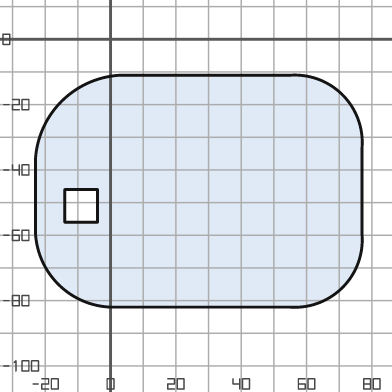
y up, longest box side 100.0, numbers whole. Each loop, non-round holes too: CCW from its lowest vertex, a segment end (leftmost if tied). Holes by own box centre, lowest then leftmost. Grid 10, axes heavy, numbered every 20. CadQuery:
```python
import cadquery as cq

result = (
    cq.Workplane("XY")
    .moveTo(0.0, -82.0)
    .lineTo(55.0, -82.0)
    .threePointArc((71.0, -76.0), (77.0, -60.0))
    .lineTo(77.0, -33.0)
    .threePointArc((71.0, -17.0), (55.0, -11.0))
    .lineTo(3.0, -11.0)
    .threePointArc((-15.0, -19.0), (-23.0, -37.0))
    .lineTo(-23.0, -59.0)
    .threePointArc((-16.0, -75.0), (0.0, -82.0))
    .close()
    .moveTo(-14.0, -56.0)
    .lineTo(-4.0, -56.0)
    .lineTo(-4.0, -46.0)
    .lineTo(-14.0, -46.0)
    .close()
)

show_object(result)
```